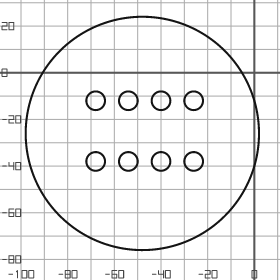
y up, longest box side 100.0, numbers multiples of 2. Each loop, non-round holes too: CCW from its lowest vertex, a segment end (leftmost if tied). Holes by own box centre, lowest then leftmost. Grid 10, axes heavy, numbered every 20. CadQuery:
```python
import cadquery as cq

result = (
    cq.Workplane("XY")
    .moveTo(-48.0, -26.0)
    .circle(50.0)
    .moveTo(-68.0, -38.0)
    .circle(4.0)
    .moveTo(-54.0, -38.0)
    .circle(4.0)
    .moveTo(-40.0, -38.0)
    .circle(4.0)
    .moveTo(-26.0, -38.0)
    .circle(4.0)
    .moveTo(-68.0, -12.0)
    .circle(4.0)
    .moveTo(-54.0, -12.0)
    .circle(4.0)
    .moveTo(-40.0, -12.0)
    .circle(4.0)
    .moveTo(-26.0, -12.0)
    .circle(4.0)
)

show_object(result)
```